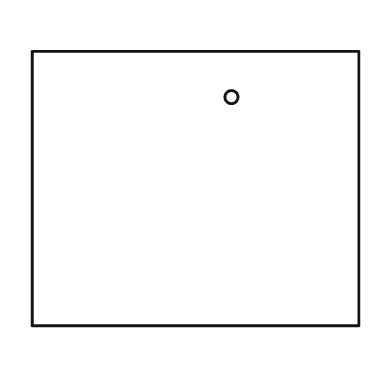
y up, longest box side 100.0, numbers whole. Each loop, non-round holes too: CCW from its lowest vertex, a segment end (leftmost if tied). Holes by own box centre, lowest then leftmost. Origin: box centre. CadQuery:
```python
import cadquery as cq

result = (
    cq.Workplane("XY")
    .moveTo(-50.0, -42.0)
    .lineTo(50.0, -42.0)
    .lineTo(50.0, 42.0)
    .lineTo(-50.0, 42.0)
    .close()
    .moveTo(11.0, 28.0)
    .circle(2.0)
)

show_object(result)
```